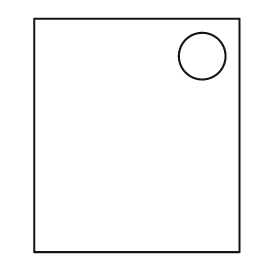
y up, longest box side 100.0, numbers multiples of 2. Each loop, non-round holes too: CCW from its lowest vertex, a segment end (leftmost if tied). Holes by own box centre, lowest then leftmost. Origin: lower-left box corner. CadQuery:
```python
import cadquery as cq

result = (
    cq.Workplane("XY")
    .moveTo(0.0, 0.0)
    .lineTo(88.0, 0.0)
    .lineTo(88.0, 100.0)
    .lineTo(0.0, 100.0)
    .close()
    .moveTo(72.0, 84.0)
    .circle(10.0)
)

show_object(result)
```